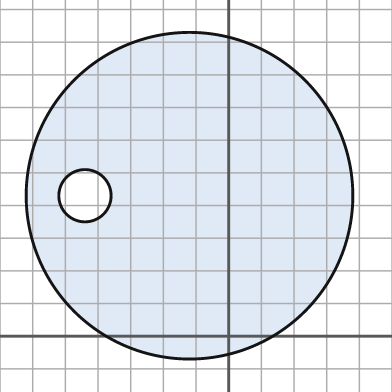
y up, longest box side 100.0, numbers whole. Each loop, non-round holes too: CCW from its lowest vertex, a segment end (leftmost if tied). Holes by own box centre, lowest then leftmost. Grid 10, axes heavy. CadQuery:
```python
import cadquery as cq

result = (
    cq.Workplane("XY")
    .moveTo(-12.0, 43.0)
    .circle(50.0)
    .moveTo(-44.0, 43.0)
    .circle(8.0)
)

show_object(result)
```